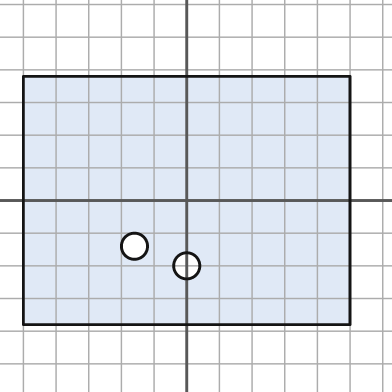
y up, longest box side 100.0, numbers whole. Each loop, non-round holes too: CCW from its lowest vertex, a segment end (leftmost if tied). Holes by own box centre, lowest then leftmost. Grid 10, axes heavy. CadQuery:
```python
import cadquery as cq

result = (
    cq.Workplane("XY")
    .moveTo(-50.0, -38.0)
    .lineTo(50.0, -38.0)
    .lineTo(50.0, 38.0)
    .lineTo(-50.0, 38.0)
    .close()
    .moveTo(0.0, -20.0)
    .circle(4.0)
    .moveTo(-16.0, -14.0)
    .circle(4.0)
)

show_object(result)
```